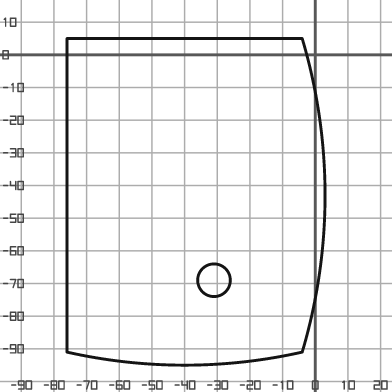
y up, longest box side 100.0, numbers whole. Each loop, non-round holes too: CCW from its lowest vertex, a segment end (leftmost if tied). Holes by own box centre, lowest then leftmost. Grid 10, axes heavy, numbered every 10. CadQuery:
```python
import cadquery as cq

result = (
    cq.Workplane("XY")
    .moveTo(-76.0, -91.0)
    .threePointArc((-40.0, -95.0), (-4.0, -91.0))
    .threePointArc((3.0, -43.0), (-4.0, 5.0))
    .lineTo(-76.0, 5.0)
    .close()
    .moveTo(-31.0, -69.0)
    .circle(5.0)
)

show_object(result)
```